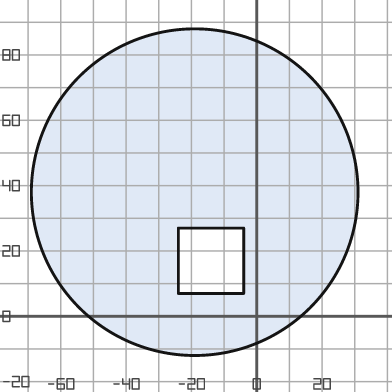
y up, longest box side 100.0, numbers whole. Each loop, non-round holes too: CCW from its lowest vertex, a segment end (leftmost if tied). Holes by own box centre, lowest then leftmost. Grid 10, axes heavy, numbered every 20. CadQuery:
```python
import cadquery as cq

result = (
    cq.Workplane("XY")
    .moveTo(-19.0, 38.0)
    .circle(50.0)
    .moveTo(-24.0, 7.0)
    .lineTo(-4.0, 7.0)
    .lineTo(-4.0, 27.0)
    .lineTo(-24.0, 27.0)
    .close()
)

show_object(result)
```